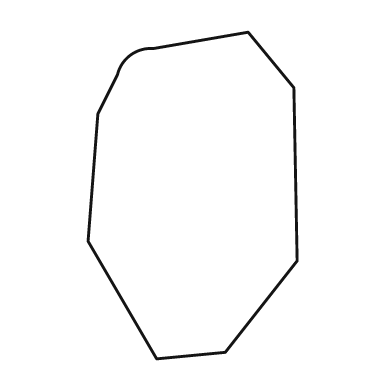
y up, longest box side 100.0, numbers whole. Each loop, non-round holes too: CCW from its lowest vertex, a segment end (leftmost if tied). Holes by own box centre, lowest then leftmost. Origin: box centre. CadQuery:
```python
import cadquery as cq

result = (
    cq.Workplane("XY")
    .moveTo(-11.0, -50.0)
    .lineTo(10.0, -48.0)
    .lineTo(32.0, -20.0)
    .lineTo(31.0, 33.0)
    .lineTo(17.0, 50.0)
    .lineTo(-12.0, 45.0)
    .threePointArc((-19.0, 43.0), (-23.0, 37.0))
    .lineTo(-29.0, 25.0)
    .lineTo(-32.0, -14.0)
    .close()
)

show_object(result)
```